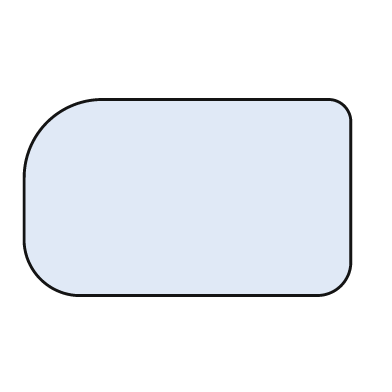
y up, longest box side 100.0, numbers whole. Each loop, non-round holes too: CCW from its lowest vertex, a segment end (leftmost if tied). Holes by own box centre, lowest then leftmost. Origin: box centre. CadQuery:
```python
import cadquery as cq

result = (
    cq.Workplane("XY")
    .moveTo(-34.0, -30.0)
    .lineTo(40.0, -30.0)
    .threePointArc((47.0, -27.0), (50.0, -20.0))
    .lineTo(50.0, 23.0)
    .threePointArc((48.0, 28.0), (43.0, 30.0))
    .lineTo(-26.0, 30.0)
    .threePointArc((-43.0, 23.0), (-50.0, 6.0))
    .lineTo(-50.0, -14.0)
    .threePointArc((-45.0, -25.0), (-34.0, -30.0))
    .close()
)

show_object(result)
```